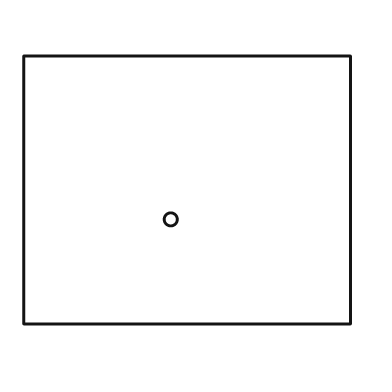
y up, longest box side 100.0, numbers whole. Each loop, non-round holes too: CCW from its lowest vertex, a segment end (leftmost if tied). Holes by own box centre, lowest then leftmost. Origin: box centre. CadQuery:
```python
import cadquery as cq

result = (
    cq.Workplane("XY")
    .moveTo(-50.0, -41.0)
    .lineTo(50.0, -41.0)
    .lineTo(50.0, 41.0)
    .lineTo(-50.0, 41.0)
    .close()
    .moveTo(-5.0, -9.0)
    .circle(2.0)
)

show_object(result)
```